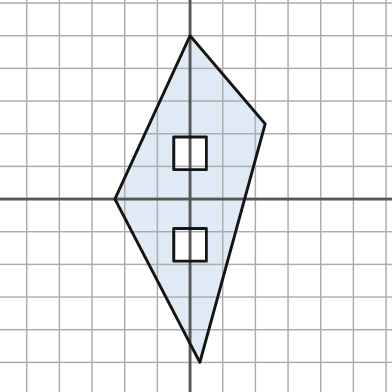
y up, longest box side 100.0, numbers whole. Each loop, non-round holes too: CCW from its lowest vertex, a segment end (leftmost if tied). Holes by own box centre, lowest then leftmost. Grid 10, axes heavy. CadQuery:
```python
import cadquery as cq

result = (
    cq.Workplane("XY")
    .moveTo(3.0, -50.0)
    .lineTo(23.0, 23.0)
    .lineTo(0.0, 50.0)
    .lineTo(-23.0, 0.0)
    .close()
    .moveTo(-5.0, -19.0)
    .lineTo(5.0, -19.0)
    .lineTo(5.0, -9.0)
    .lineTo(-5.0, -9.0)
    .close()
    .moveTo(-5.0, 9.0)
    .lineTo(5.0, 9.0)
    .lineTo(5.0, 19.0)
    .lineTo(-5.0, 19.0)
    .close()
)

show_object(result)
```